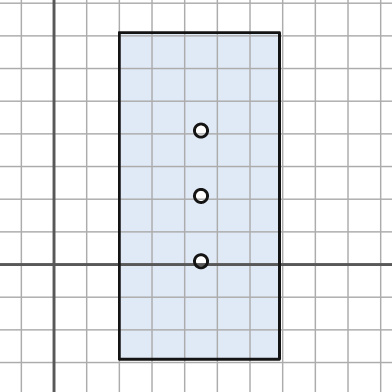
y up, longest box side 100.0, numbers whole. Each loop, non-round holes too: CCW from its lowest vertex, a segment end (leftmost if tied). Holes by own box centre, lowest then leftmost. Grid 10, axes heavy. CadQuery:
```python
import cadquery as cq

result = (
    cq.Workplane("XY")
    .moveTo(20.0, -29.0)
    .lineTo(69.0, -29.0)
    .lineTo(69.0, 71.0)
    .lineTo(20.0, 71.0)
    .close()
    .moveTo(45.0, 1.0)
    .circle(2.0)
    .moveTo(45.0, 21.0)
    .circle(2.0)
    .moveTo(45.0, 41.0)
    .circle(2.0)
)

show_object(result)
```